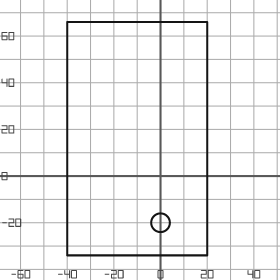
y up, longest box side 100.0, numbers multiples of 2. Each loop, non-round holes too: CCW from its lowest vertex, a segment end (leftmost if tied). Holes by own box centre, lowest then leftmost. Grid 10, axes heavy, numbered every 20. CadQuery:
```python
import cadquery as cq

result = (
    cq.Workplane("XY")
    .moveTo(-40.0, -34.0)
    .lineTo(20.0, -34.0)
    .lineTo(20.0, 66.0)
    .lineTo(-40.0, 66.0)
    .close()
    .moveTo(0.0, -20.0)
    .circle(4.0)
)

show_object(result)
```